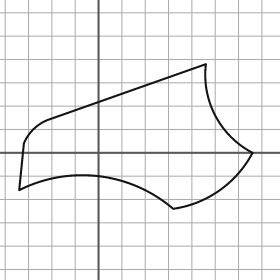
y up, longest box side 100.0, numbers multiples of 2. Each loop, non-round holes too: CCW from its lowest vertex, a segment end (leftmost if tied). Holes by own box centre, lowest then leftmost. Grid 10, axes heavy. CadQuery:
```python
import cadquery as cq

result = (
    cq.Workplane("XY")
    .moveTo(32.0, -24.0)
    .threePointArc((52.0, -16.0), (66.0, 0.0))
    .threePointArc((50.0, 16.0), (46.0, 38.0))
    .lineTo(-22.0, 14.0)
    .threePointArc((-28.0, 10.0), (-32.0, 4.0))
    .lineTo(-34.0, -16.0)
    .threePointArc((0.0, -10.0), (32.0, -24.0))
    .close()
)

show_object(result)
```